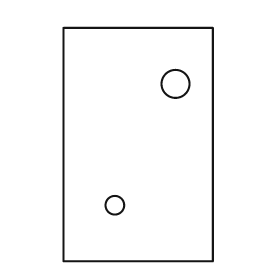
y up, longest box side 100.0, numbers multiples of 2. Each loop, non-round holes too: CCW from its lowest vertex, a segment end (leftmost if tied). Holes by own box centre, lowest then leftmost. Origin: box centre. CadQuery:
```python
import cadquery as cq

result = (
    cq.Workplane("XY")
    .moveTo(-32.0, -50.0)
    .lineTo(32.0, -50.0)
    .lineTo(32.0, 50.0)
    .lineTo(-32.0, 50.0)
    .close()
    .moveTo(-10.0, -26.0)
    .circle(4.0)
    .moveTo(16.0, 26.0)
    .circle(6.0)
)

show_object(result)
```